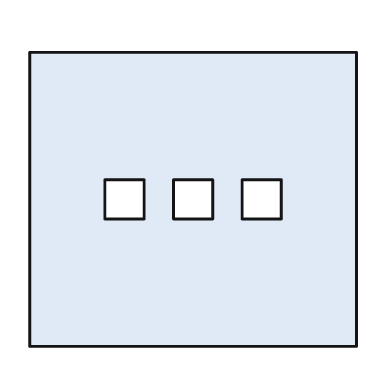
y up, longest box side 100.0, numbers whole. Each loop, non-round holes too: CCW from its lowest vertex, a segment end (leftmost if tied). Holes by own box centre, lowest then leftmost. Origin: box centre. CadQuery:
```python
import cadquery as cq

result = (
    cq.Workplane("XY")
    .moveTo(-50.0, -45.0)
    .lineTo(50.0, -45.0)
    .lineTo(50.0, 45.0)
    .lineTo(-50.0, 45.0)
    .close()
    .moveTo(-27.0, -6.0)
    .lineTo(-15.0, -6.0)
    .lineTo(-15.0, 6.0)
    .lineTo(-27.0, 6.0)
    .close()
    .moveTo(-6.0, -6.0)
    .lineTo(6.0, -6.0)
    .lineTo(6.0, 6.0)
    .lineTo(-6.0, 6.0)
    .close()
    .moveTo(15.0, -6.0)
    .lineTo(27.0, -6.0)
    .lineTo(27.0, 6.0)
    .lineTo(15.0, 6.0)
    .close()
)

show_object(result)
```